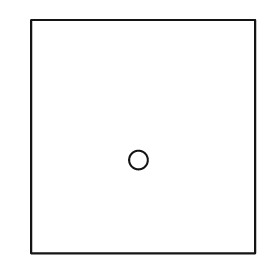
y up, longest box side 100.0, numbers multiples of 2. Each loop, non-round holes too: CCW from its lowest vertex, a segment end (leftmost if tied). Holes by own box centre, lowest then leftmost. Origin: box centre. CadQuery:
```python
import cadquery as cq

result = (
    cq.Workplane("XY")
    .moveTo(-48.0, -50.0)
    .lineTo(48.0, -50.0)
    .lineTo(48.0, 50.0)
    .lineTo(-48.0, 50.0)
    .close()
    .moveTo(-2.0, -10.0)
    .circle(4.0)
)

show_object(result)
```